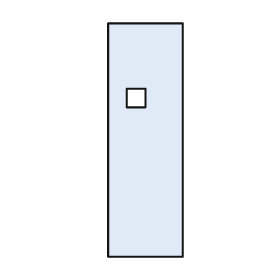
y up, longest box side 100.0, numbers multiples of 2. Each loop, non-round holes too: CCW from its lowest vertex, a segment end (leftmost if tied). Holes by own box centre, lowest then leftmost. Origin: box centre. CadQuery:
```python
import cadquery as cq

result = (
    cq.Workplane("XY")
    .moveTo(-16.0, -50.0)
    .lineTo(16.0, -50.0)
    .lineTo(16.0, 50.0)
    .lineTo(-16.0, 50.0)
    .close()
    .moveTo(-8.0, 14.0)
    .lineTo(0.0, 14.0)
    .lineTo(0.0, 22.0)
    .lineTo(-8.0, 22.0)
    .close()
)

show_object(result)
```